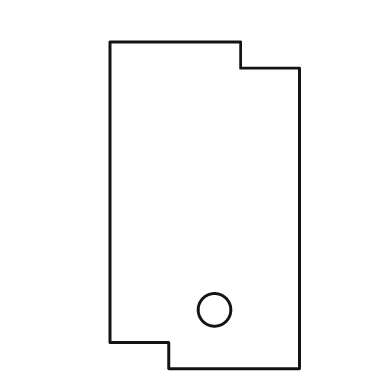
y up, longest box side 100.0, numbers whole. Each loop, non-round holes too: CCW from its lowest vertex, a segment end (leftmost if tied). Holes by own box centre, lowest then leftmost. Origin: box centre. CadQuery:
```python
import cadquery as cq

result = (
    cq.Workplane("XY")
    .moveTo(-11.0, -50.0)
    .lineTo(29.0, -50.0)
    .lineTo(29.0, 42.0)
    .lineTo(11.0, 42.0)
    .lineTo(11.0, 50.0)
    .lineTo(-29.0, 50.0)
    .lineTo(-29.0, -42.0)
    .lineTo(-11.0, -42.0)
    .close()
    .moveTo(3.0, -32.0)
    .circle(5.0)
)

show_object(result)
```